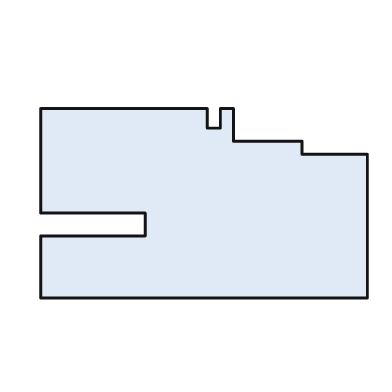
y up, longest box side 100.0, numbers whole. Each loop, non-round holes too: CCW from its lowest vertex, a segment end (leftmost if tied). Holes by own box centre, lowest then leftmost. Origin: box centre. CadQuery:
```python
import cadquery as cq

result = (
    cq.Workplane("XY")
    .moveTo(-50.0, -29.0)
    .lineTo(50.0, -29.0)
    .lineTo(50.0, 15.0)
    .lineTo(30.0, 15.0)
    .lineTo(30.0, 19.0)
    .lineTo(9.0, 19.0)
    .lineTo(9.0, 29.0)
    .lineTo(5.0, 29.0)
    .lineTo(5.0, 23.0)
    .lineTo(1.0, 23.0)
    .lineTo(1.0, 29.0)
    .lineTo(-50.0, 29.0)
    .lineTo(-50.0, -3.0)
    .lineTo(-18.0, -3.0)
    .lineTo(-18.0, -10.0)
    .lineTo(-50.0, -10.0)
    .close()
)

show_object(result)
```